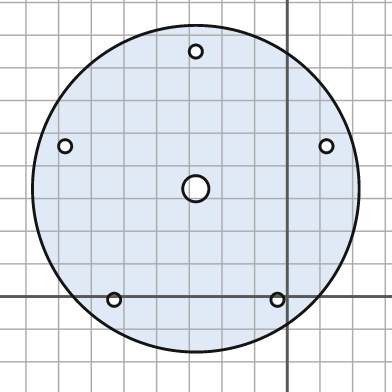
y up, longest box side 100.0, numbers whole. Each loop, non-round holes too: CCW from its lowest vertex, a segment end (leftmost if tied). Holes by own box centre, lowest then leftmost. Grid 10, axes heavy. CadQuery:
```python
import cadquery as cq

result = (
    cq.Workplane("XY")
    .moveTo(-28.0, 33.0)
    .circle(50.0)
    .moveTo(-53.0, -1.0)
    .circle(2.0)
    .moveTo(-3.0, -1.0)
    .circle(2.0)
    .moveTo(-28.0, 33.0)
    .circle(4.0)
    .moveTo(-68.0, 46.0)
    .circle(2.0)
    .moveTo(12.0, 46.0)
    .circle(2.0)
    .moveTo(-28.0, 75.0)
    .circle(2.0)
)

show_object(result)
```